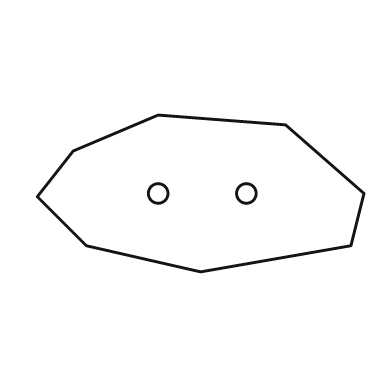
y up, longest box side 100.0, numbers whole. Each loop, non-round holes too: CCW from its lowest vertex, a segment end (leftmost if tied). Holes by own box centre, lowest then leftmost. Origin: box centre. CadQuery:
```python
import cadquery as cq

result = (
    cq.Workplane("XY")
    .moveTo(0.0, -24.0)
    .lineTo(46.0, -16.0)
    .lineTo(50.0, 0.0)
    .lineTo(26.0, 21.0)
    .lineTo(-13.0, 24.0)
    .lineTo(-39.0, 13.0)
    .lineTo(-50.0, -1.0)
    .lineTo(-35.0, -16.0)
    .close()
    .moveTo(-13.0, 0.0)
    .circle(3.0)
    .moveTo(14.0, 0.0)
    .circle(3.0)
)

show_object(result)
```